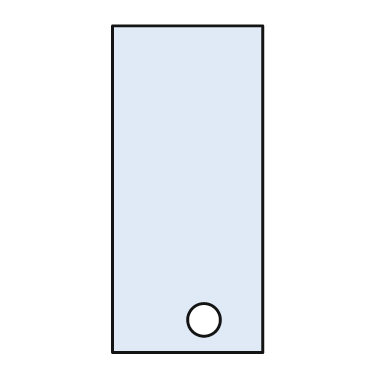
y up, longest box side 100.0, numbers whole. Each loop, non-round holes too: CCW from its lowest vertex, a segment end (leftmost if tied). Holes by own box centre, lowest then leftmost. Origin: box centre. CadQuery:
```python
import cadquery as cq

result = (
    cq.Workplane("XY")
    .moveTo(-23.0, -50.0)
    .lineTo(23.0, -50.0)
    .lineTo(23.0, 50.0)
    .lineTo(-23.0, 50.0)
    .close()
    .moveTo(5.0, -40.0)
    .circle(5.0)
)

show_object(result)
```